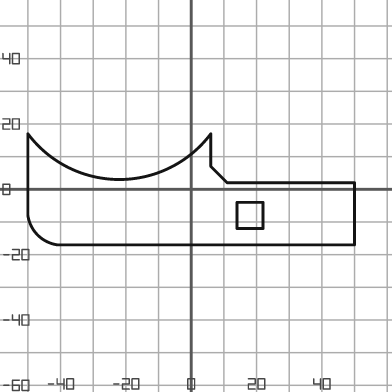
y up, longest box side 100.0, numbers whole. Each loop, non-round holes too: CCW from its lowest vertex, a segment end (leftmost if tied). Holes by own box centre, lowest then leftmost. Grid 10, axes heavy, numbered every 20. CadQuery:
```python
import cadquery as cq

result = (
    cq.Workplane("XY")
    .moveTo(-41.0, -17.0)
    .lineTo(50.0, -17.0)
    .lineTo(50.0, 2.0)
    .lineTo(11.0, 2.0)
    .lineTo(6.0, 7.0)
    .lineTo(6.0, 17.0)
    .threePointArc((-22.0, 3.0), (-50.0, 17.0))
    .lineTo(-50.0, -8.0)
    .threePointArc((-47.0, -14.0), (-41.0, -17.0))
    .close()
    .moveTo(14.0, -12.0)
    .lineTo(22.0, -12.0)
    .lineTo(22.0, -4.0)
    .lineTo(14.0, -4.0)
    .close()
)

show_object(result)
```